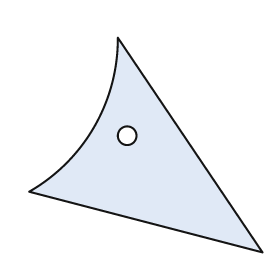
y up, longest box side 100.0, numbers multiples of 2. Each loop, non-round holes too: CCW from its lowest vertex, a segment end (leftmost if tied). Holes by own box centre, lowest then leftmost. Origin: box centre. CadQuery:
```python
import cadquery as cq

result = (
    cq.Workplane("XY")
    .moveTo(50.0, -46.0)
    .lineTo(-12.0, 46.0)
    .threePointArc((-22.0, 8.0), (-50.0, -20.0))
    .close()
    .moveTo(-8.0, 4.0)
    .circle(4.0)
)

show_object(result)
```